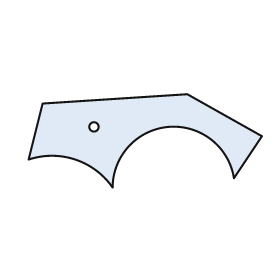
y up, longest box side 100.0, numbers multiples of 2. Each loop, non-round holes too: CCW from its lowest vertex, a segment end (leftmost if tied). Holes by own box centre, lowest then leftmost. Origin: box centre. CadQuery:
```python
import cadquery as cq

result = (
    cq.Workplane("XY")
    .moveTo(-14.0, -20.0)
    .threePointArc((10.0, 6.0), (38.0, -16.0))
    .lineTo(50.0, 2.0)
    .lineTo(18.0, 20.0)
    .lineTo(-44.0, 16.0)
    .lineTo(-50.0, -8.0)
    .threePointArc((-30.0, -8.0), (-14.0, -20.0))
    .close()
    .moveTo(-22.0, 6.0)
    .circle(2.0)
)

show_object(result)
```